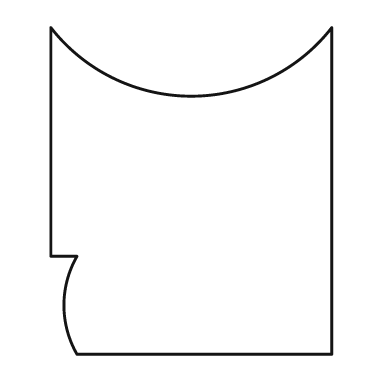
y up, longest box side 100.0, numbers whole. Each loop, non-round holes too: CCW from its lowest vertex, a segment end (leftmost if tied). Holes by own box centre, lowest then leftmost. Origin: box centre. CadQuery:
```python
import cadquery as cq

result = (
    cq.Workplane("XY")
    .moveTo(-35.0, -50.0)
    .lineTo(43.0, -50.0)
    .lineTo(43.0, 50.0)
    .threePointArc((0.0, 29.0), (-43.0, 50.0))
    .lineTo(-43.0, -20.0)
    .lineTo(-35.0, -20.0)
    .threePointArc((-39.0, -35.0), (-35.0, -50.0))
    .close()
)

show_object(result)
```